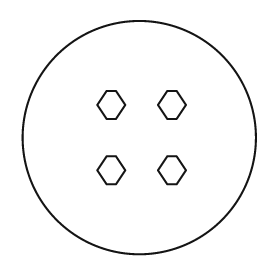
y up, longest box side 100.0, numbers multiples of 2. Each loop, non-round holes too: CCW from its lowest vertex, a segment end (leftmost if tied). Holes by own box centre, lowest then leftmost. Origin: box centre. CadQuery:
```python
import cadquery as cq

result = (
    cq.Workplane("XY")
    .moveTo(0.0, 0.0)
    .circle(50.0)
    .moveTo(-14.0, -20.0)
    .lineTo(-10.0, -20.0)
    .lineTo(-6.0, -14.0)
    .lineTo(-10.0, -8.0)
    .lineTo(-14.0, -8.0)
    .lineTo(-18.0, -14.0)
    .close()
    .moveTo(12.0, -20.0)
    .lineTo(16.0, -20.0)
    .lineTo(20.0, -14.0)
    .lineTo(16.0, -8.0)
    .lineTo(12.0, -8.0)
    .lineTo(8.0, -14.0)
    .close()
    .moveTo(-14.0, 8.0)
    .lineTo(-10.0, 8.0)
    .lineTo(-6.0, 14.0)
    .lineTo(-10.0, 20.0)
    .lineTo(-14.0, 20.0)
    .lineTo(-18.0, 14.0)
    .close()
    .moveTo(12.0, 8.0)
    .lineTo(16.0, 8.0)
    .lineTo(20.0, 14.0)
    .lineTo(16.0, 20.0)
    .lineTo(12.0, 20.0)
    .lineTo(8.0, 14.0)
    .close()
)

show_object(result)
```